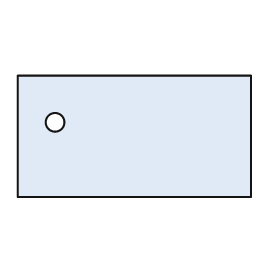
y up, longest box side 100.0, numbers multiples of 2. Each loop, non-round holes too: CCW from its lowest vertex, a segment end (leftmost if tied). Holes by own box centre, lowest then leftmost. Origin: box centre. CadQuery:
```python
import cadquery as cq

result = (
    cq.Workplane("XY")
    .moveTo(-50.0, -26.0)
    .lineTo(50.0, -26.0)
    .lineTo(50.0, 26.0)
    .lineTo(-50.0, 26.0)
    .close()
    .moveTo(-34.0, 6.0)
    .circle(4.0)
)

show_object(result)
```